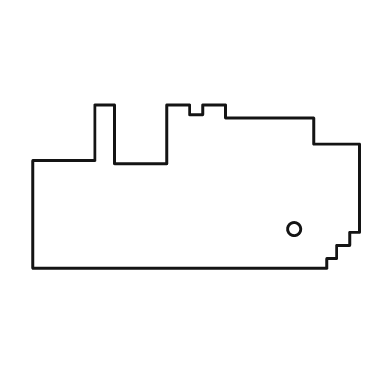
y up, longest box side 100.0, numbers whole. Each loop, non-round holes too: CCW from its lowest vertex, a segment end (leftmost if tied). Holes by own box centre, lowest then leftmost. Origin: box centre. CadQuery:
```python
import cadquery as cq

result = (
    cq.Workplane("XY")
    .moveTo(-50.0, -25.0)
    .lineTo(40.0, -25.0)
    .lineTo(40.0, -22.0)
    .lineTo(43.0, -22.0)
    .lineTo(43.0, -18.0)
    .lineTo(47.0, -18.0)
    .lineTo(47.0, -14.0)
    .lineTo(50.0, -14.0)
    .lineTo(50.0, 13.0)
    .lineTo(36.0, 13.0)
    .lineTo(36.0, 21.0)
    .lineTo(9.0, 21.0)
    .lineTo(9.0, 25.0)
    .lineTo(2.0, 25.0)
    .lineTo(2.0, 22.0)
    .lineTo(-2.0, 22.0)
    .lineTo(-2.0, 25.0)
    .lineTo(-9.0, 25.0)
    .lineTo(-9.0, 7.0)
    .lineTo(-25.0, 7.0)
    .lineTo(-25.0, 25.0)
    .lineTo(-31.0, 25.0)
    .lineTo(-31.0, 8.0)
    .lineTo(-50.0, 8.0)
    .close()
    .moveTo(30.0, -13.0)
    .circle(2.0)
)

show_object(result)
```